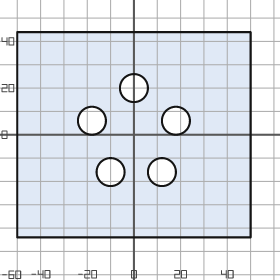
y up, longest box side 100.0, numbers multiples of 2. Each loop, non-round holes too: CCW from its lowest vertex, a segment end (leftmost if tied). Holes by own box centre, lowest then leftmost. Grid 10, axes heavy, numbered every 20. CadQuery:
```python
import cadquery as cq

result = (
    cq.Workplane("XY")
    .moveTo(-50.0, -44.0)
    .lineTo(50.0, -44.0)
    .lineTo(50.0, 44.0)
    .lineTo(-50.0, 44.0)
    .close()
    .moveTo(-10.0, -16.0)
    .circle(6.0)
    .moveTo(12.0, -16.0)
    .circle(6.0)
    .moveTo(-18.0, 6.0)
    .circle(6.0)
    .moveTo(18.0, 6.0)
    .circle(6.0)
    .moveTo(0.0, 20.0)
    .circle(6.0)
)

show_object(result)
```